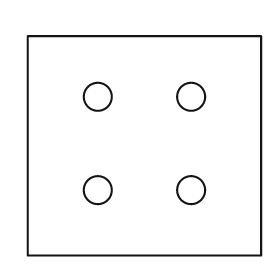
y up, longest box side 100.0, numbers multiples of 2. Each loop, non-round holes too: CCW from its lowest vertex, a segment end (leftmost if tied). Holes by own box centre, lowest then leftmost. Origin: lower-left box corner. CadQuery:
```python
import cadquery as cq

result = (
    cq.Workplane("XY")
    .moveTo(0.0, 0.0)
    .lineTo(100.0, 0.0)
    .lineTo(100.0, 94.0)
    .lineTo(0.0, 94.0)
    .close()
    .moveTo(30.0, 28.0)
    .circle(6.0)
    .moveTo(70.0, 28.0)
    .circle(6.0)
    .moveTo(30.0, 68.0)
    .circle(6.0)
    .moveTo(70.0, 68.0)
    .circle(6.0)
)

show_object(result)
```